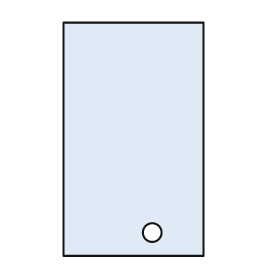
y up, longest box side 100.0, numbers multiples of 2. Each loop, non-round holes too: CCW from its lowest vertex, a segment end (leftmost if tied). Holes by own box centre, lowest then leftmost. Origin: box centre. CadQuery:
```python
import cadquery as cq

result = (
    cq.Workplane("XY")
    .moveTo(-30.0, -50.0)
    .lineTo(30.0, -50.0)
    .lineTo(30.0, 50.0)
    .lineTo(-30.0, 50.0)
    .close()
    .moveTo(8.0, -40.0)
    .circle(4.0)
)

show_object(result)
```